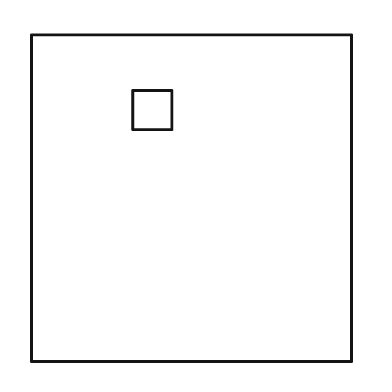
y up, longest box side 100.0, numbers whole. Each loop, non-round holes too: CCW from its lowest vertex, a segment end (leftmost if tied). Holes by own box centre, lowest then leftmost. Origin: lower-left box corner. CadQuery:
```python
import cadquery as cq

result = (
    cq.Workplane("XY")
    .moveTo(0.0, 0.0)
    .lineTo(98.0, 0.0)
    .lineTo(98.0, 100.0)
    .lineTo(0.0, 100.0)
    .close()
    .moveTo(31.0, 71.0)
    .lineTo(43.0, 71.0)
    .lineTo(43.0, 83.0)
    .lineTo(31.0, 83.0)
    .close()
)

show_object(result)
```